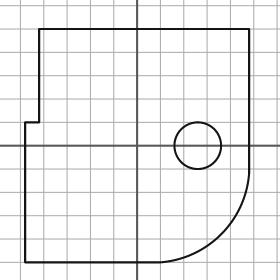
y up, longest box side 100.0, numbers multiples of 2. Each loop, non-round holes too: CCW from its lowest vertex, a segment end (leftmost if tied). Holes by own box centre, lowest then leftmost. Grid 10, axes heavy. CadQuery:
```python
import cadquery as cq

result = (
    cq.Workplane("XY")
    .moveTo(-48.0, -50.0)
    .lineTo(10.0, -50.0)
    .threePointArc((36.0, -38.0), (48.0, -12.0))
    .lineTo(48.0, 50.0)
    .lineTo(-42.0, 50.0)
    .lineTo(-42.0, 10.0)
    .lineTo(-48.0, 10.0)
    .close()
    .moveTo(26.0, 0.0)
    .circle(10.0)
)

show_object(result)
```